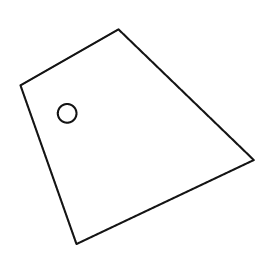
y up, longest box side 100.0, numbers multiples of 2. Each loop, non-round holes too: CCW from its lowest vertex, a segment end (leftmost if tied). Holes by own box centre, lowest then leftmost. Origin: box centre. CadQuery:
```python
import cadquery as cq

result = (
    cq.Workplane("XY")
    .moveTo(-26.0, -46.0)
    .lineTo(50.0, -10.0)
    .lineTo(-8.0, 46.0)
    .lineTo(-50.0, 22.0)
    .close()
    .moveTo(-30.0, 10.0)
    .circle(4.0)
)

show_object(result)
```